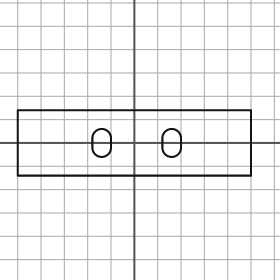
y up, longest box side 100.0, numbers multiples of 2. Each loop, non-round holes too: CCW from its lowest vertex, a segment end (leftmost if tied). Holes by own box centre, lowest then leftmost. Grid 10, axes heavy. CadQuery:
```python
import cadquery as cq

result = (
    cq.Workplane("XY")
    .moveTo(-50.0, -14.0)
    .lineTo(50.0, -14.0)
    .lineTo(50.0, 14.0)
    .lineTo(-50.0, 14.0)
    .close()
    .moveTo(-18.0, -2.0)
    .threePointArc((-14.0, -6.0), (-10.0, -2.0))
    .lineTo(-10.0, 2.0)
    .threePointArc((-14.0, 6.0), (-18.0, 2.0))
    .close()
    .moveTo(12.0, -2.0)
    .threePointArc((16.0, -6.0), (20.0, -2.0))
    .lineTo(20.0, 2.0)
    .threePointArc((16.0, 6.0), (12.0, 2.0))
    .close()
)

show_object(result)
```